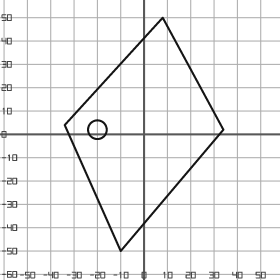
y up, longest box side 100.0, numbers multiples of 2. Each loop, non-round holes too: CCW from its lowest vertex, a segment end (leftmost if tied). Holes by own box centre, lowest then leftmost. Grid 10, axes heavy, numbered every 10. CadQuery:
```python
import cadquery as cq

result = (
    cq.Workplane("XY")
    .moveTo(-10.0, -50.0)
    .lineTo(34.0, 2.0)
    .lineTo(8.0, 50.0)
    .lineTo(-34.0, 4.0)
    .close()
    .moveTo(-20.0, 2.0)
    .circle(4.0)
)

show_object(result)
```